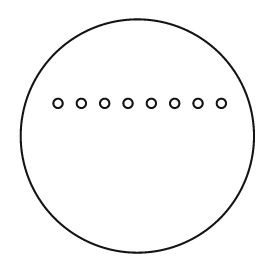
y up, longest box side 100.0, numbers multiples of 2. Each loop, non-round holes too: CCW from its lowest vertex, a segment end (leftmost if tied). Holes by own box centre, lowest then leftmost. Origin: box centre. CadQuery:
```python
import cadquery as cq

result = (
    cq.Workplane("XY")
    .moveTo(0.0, 0.0)
    .circle(50.0)
    .moveTo(-34.0, 14.0)
    .circle(2.0)
    .moveTo(-24.0, 14.0)
    .circle(2.0)
    .moveTo(-14.0, 14.0)
    .circle(2.0)
    .moveTo(-4.0, 14.0)
    .circle(2.0)
    .moveTo(6.0, 14.0)
    .circle(2.0)
    .moveTo(16.0, 14.0)
    .circle(2.0)
    .moveTo(26.0, 14.0)
    .circle(2.0)
    .moveTo(36.0, 14.0)
    .circle(2.0)
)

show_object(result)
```